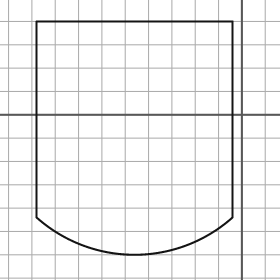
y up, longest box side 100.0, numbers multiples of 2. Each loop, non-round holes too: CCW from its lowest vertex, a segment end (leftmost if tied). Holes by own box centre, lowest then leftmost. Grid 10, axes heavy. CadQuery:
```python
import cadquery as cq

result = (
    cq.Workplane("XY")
    .moveTo(-88.0, -44.0)
    .threePointArc((-46.0, -60.0), (-4.0, -44.0))
    .lineTo(-4.0, 40.0)
    .lineTo(-88.0, 40.0)
    .close()
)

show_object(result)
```